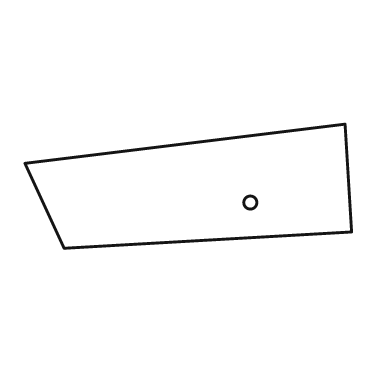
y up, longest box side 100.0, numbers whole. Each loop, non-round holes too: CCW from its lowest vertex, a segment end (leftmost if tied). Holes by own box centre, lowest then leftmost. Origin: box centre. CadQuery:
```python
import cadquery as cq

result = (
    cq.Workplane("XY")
    .moveTo(-38.0, -19.0)
    .lineTo(50.0, -14.0)
    .lineTo(48.0, 19.0)
    .lineTo(-50.0, 7.0)
    .close()
    .moveTo(19.0, -5.0)
    .circle(2.0)
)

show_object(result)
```